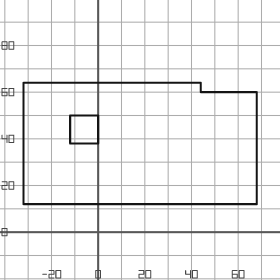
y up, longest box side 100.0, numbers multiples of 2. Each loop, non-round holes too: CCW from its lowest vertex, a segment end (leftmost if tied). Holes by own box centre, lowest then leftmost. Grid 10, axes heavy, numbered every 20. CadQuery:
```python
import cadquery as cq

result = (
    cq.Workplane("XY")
    .moveTo(-32.0, 12.0)
    .lineTo(68.0, 12.0)
    .lineTo(68.0, 60.0)
    .lineTo(44.0, 60.0)
    .lineTo(44.0, 64.0)
    .lineTo(-32.0, 64.0)
    .close()
    .moveTo(-12.0, 38.0)
    .lineTo(0.0, 38.0)
    .lineTo(0.0, 50.0)
    .lineTo(-12.0, 50.0)
    .close()
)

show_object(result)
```